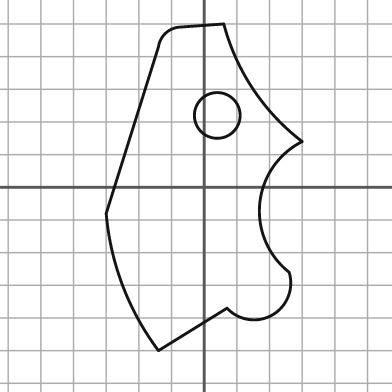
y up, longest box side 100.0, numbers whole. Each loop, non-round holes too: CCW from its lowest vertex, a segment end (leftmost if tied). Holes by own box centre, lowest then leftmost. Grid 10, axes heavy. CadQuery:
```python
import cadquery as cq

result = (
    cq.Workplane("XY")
    .moveTo(-14.0, -50.0)
    .lineTo(7.0, -37.0)
    .threePointArc((21.0, -39.0), (26.0, -26.0))
    .threePointArc((17.0, -5.0), (30.0, 14.0))
    .threePointArc((15.0, 30.0), (6.0, 50.0))
    .lineTo(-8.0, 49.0)
    .threePointArc((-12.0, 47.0), (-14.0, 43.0))
    .lineTo(-30.0, -8.0)
    .threePointArc((-25.0, -30.0), (-14.0, -50.0))
    .close()
    .moveTo(4.0, 22.0)
    .circle(7.0)
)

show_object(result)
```